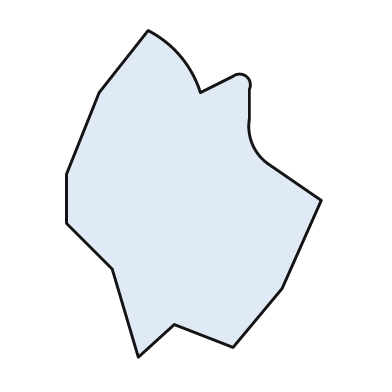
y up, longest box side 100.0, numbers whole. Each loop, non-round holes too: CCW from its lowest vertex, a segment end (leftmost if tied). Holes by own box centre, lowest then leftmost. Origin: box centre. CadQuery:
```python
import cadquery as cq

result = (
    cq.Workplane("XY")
    .moveTo(-17.0, -50.0)
    .lineTo(-6.0, -40.0)
    .lineTo(12.0, -47.0)
    .lineTo(27.0, -29.0)
    .lineTo(39.0, -2.0)
    .lineTo(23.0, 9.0)
    .threePointArc((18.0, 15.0), (17.0, 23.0))
    .lineTo(17.0, 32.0)
    .threePointArc((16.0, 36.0), (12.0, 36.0))
    .lineTo(2.0, 31.0)
    .threePointArc((-4.0, 42.0), (-14.0, 50.0))
    .lineTo(-29.0, 31.0)
    .lineTo(-39.0, 6.0)
    .lineTo(-39.0, -9.0)
    .lineTo(-25.0, -23.0)
    .close()
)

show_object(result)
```